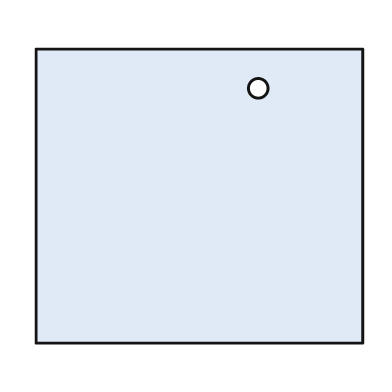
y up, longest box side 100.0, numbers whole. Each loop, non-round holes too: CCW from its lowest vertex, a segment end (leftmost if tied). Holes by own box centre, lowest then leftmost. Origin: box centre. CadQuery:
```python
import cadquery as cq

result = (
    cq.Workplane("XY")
    .moveTo(-50.0, -45.0)
    .lineTo(50.0, -45.0)
    .lineTo(50.0, 45.0)
    .lineTo(-50.0, 45.0)
    .close()
    .moveTo(18.0, 33.0)
    .circle(3.0)
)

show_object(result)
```